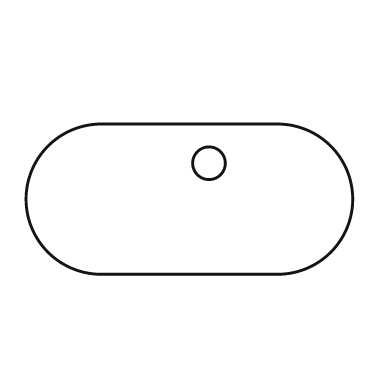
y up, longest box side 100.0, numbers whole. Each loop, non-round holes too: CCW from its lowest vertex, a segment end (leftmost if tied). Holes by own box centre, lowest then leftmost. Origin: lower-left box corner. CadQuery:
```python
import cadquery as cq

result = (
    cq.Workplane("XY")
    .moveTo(23.0, 0.0)
    .lineTo(77.0, 0.0)
    .threePointArc((100.0, 23.0), (77.0, 46.0))
    .lineTo(23.0, 46.0)
    .threePointArc((0.0, 23.0), (23.0, 0.0))
    .close()
    .moveTo(56.0, 34.0)
    .circle(5.0)
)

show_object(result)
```